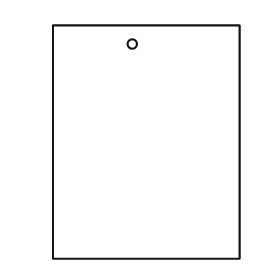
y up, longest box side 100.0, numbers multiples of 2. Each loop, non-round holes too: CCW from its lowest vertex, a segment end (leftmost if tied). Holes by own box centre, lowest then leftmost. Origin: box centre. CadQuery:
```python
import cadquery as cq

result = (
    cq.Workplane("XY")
    .moveTo(-40.0, -50.0)
    .lineTo(40.0, -50.0)
    .lineTo(40.0, 50.0)
    .lineTo(-40.0, 50.0)
    .close()
    .moveTo(-6.0, 42.0)
    .circle(2.0)
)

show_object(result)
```